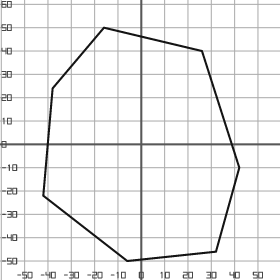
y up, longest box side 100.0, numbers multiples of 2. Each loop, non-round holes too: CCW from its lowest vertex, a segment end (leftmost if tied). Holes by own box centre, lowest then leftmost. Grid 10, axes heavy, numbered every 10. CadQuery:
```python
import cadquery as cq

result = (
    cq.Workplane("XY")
    .moveTo(-6.0, -50.0)
    .lineTo(32.0, -46.0)
    .lineTo(42.0, -10.0)
    .lineTo(26.0, 40.0)
    .lineTo(-16.0, 50.0)
    .lineTo(-38.0, 24.0)
    .lineTo(-42.0, -22.0)
    .close()
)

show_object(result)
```